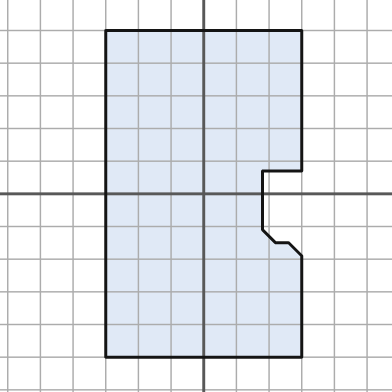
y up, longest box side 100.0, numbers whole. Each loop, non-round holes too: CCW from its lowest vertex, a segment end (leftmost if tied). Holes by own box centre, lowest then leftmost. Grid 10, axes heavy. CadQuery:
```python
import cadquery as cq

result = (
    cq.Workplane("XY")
    .moveTo(-30.0, -50.0)
    .lineTo(30.0, -50.0)
    .lineTo(30.0, -19.0)
    .lineTo(26.0, -15.0)
    .lineTo(22.0, -15.0)
    .lineTo(18.0, -11.0)
    .lineTo(18.0, 7.0)
    .lineTo(30.0, 7.0)
    .lineTo(30.0, 50.0)
    .lineTo(-30.0, 50.0)
    .close()
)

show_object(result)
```